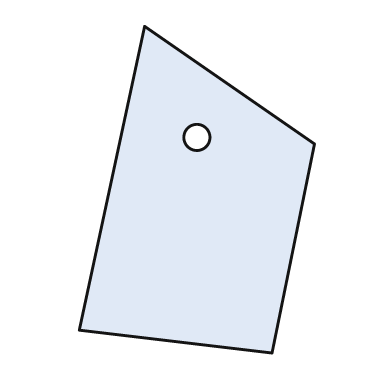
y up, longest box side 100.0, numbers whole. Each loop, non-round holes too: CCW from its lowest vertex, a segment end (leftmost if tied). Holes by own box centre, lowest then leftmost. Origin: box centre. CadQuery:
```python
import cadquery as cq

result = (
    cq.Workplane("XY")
    .moveTo(23.0, -50.0)
    .lineTo(36.0, 14.0)
    .lineTo(-16.0, 50.0)
    .lineTo(-36.0, -43.0)
    .close()
    .moveTo(0.0, 16.0)
    .circle(4.0)
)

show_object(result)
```